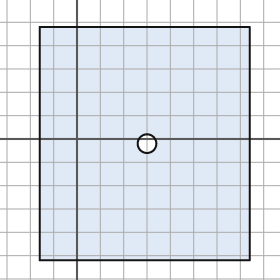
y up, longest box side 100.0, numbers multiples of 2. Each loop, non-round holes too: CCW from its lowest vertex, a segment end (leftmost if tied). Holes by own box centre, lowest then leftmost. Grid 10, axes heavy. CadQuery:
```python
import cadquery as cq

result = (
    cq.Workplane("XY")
    .moveTo(-16.0, -52.0)
    .lineTo(74.0, -52.0)
    .lineTo(74.0, 48.0)
    .lineTo(-16.0, 48.0)
    .close()
    .moveTo(30.0, -2.0)
    .circle(4.0)
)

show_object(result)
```